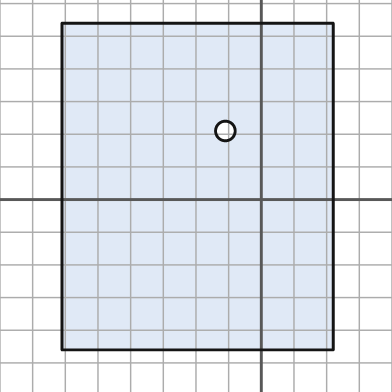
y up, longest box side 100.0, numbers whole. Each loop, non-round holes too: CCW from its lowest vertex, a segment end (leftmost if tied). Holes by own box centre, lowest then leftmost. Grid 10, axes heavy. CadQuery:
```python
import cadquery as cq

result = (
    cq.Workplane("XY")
    .moveTo(-61.0, -46.0)
    .lineTo(22.0, -46.0)
    .lineTo(22.0, 54.0)
    .lineTo(-61.0, 54.0)
    .close()
    .moveTo(-11.0, 21.0)
    .circle(3.0)
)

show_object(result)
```